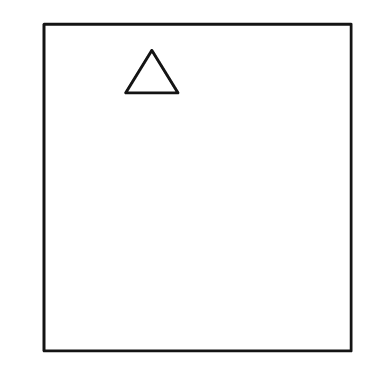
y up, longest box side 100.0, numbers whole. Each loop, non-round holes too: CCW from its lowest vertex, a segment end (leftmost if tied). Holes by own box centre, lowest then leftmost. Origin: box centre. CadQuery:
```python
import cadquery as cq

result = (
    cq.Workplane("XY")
    .moveTo(-47.0, -50.0)
    .lineTo(47.0, -50.0)
    .lineTo(47.0, 50.0)
    .lineTo(-47.0, 50.0)
    .close()
    .moveTo(-22.0, 29.0)
    .lineTo(-6.0, 29.0)
    .lineTo(-14.0, 42.0)
    .close()
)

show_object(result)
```